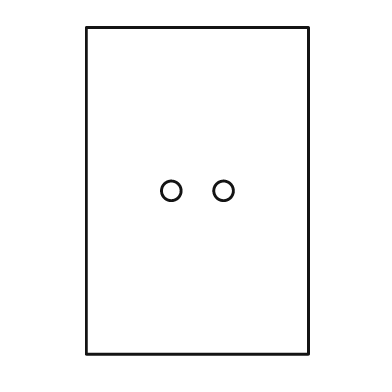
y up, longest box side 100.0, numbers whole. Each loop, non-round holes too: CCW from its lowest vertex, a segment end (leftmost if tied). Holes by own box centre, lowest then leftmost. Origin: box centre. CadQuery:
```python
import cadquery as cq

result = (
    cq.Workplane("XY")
    .moveTo(-34.0, -50.0)
    .lineTo(34.0, -50.0)
    .lineTo(34.0, 50.0)
    .lineTo(-34.0, 50.0)
    .close()
    .moveTo(-8.0, 0.0)
    .circle(3.0)
    .moveTo(8.0, 0.0)
    .circle(3.0)
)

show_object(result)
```